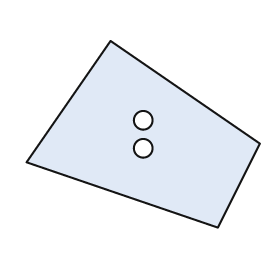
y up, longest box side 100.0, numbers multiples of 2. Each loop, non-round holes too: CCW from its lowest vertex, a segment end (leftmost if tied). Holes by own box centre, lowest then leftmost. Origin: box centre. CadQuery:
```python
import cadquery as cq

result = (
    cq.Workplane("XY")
    .moveTo(32.0, -40.0)
    .lineTo(50.0, -4.0)
    .lineTo(-14.0, 40.0)
    .lineTo(-50.0, -12.0)
    .close()
    .moveTo(0.0, -6.0)
    .circle(4.0)
    .moveTo(0.0, 6.0)
    .circle(4.0)
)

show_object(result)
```